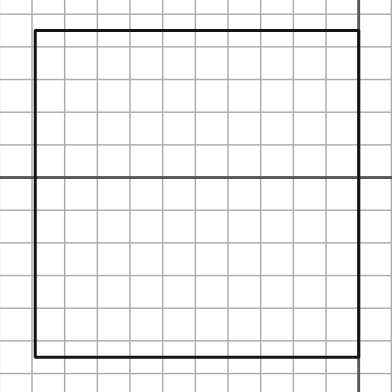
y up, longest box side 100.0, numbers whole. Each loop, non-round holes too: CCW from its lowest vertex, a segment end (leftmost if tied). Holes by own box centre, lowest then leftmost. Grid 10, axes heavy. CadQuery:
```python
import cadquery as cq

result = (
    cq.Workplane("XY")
    .moveTo(-99.0, -55.0)
    .lineTo(0.0, -55.0)
    .lineTo(0.0, 45.0)
    .lineTo(-99.0, 45.0)
    .close()
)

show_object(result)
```